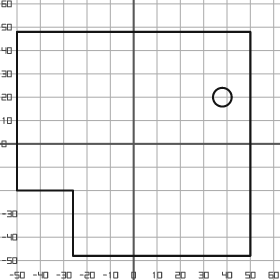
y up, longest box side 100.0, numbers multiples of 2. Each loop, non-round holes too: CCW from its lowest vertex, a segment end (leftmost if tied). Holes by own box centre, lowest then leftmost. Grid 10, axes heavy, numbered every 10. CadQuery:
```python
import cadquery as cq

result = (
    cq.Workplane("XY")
    .moveTo(-26.0, -48.0)
    .lineTo(50.0, -48.0)
    .lineTo(50.0, 48.0)
    .lineTo(-50.0, 48.0)
    .lineTo(-50.0, -20.0)
    .lineTo(-26.0, -20.0)
    .close()
    .moveTo(38.0, 20.0)
    .circle(4.0)
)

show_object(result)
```